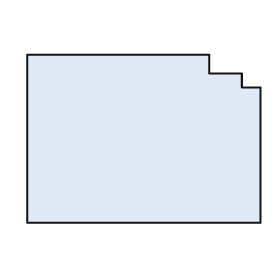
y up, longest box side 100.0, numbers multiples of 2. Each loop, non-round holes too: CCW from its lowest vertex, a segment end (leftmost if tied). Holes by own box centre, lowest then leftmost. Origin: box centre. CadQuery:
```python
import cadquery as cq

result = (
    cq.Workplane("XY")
    .moveTo(-50.0, -36.0)
    .lineTo(50.0, -36.0)
    .lineTo(50.0, 22.0)
    .lineTo(42.0, 22.0)
    .lineTo(42.0, 28.0)
    .lineTo(28.0, 28.0)
    .lineTo(28.0, 36.0)
    .lineTo(-50.0, 36.0)
    .close()
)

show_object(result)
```